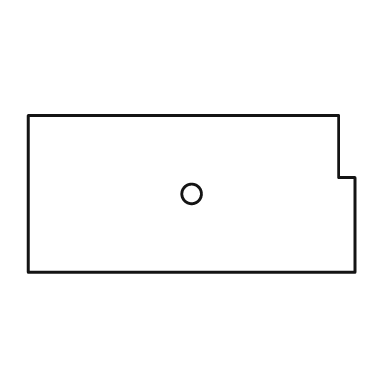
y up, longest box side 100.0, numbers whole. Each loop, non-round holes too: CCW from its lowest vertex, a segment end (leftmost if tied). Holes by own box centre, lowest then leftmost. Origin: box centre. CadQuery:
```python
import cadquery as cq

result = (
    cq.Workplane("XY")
    .moveTo(-50.0, -24.0)
    .lineTo(50.0, -24.0)
    .lineTo(50.0, 5.0)
    .lineTo(45.0, 5.0)
    .lineTo(45.0, 24.0)
    .lineTo(-50.0, 24.0)
    .close()
    .moveTo(0.0, 0.0)
    .circle(3.0)
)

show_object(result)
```